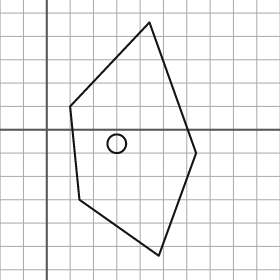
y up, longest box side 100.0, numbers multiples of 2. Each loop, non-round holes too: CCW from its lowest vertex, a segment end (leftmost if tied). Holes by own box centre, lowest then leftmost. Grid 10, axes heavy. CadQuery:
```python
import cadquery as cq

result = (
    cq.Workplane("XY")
    .moveTo(48.0, -54.0)
    .lineTo(64.0, -10.0)
    .lineTo(44.0, 46.0)
    .lineTo(10.0, 10.0)
    .lineTo(14.0, -30.0)
    .close()
    .moveTo(30.0, -6.0)
    .circle(4.0)
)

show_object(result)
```